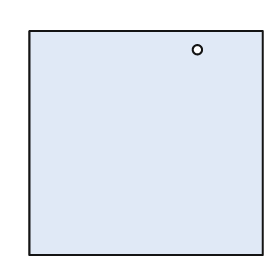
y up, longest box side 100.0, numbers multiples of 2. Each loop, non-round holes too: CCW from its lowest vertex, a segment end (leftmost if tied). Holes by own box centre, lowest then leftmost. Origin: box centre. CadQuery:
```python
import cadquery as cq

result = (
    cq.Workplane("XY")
    .moveTo(-50.0, -48.0)
    .lineTo(50.0, -48.0)
    .lineTo(50.0, 48.0)
    .lineTo(-50.0, 48.0)
    .close()
    .moveTo(22.0, 40.0)
    .circle(2.0)
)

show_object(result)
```